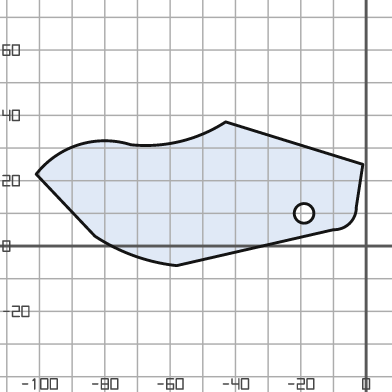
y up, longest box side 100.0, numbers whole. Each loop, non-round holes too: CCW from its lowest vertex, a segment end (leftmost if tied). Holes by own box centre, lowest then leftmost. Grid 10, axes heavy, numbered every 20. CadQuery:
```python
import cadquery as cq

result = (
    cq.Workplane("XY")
    .moveTo(-58.0, -6.0)
    .lineTo(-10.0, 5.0)
    .threePointArc((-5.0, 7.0), (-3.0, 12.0))
    .lineTo(-1.0, 25.0)
    .lineTo(-43.0, 38.0)
    .threePointArc((-57.0, 32.0), (-72.0, 31.0))
    .threePointArc((-88.0, 31.0), (-101.0, 22.0))
    .lineTo(-83.0, 3.0)
    .threePointArc((-71.0, -3.0), (-58.0, -6.0))
    .close()
    .moveTo(-19.0, 10.0)
    .circle(3.0)
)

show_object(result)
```